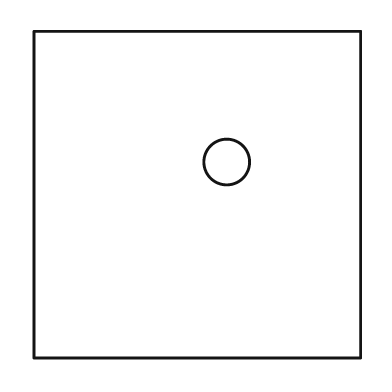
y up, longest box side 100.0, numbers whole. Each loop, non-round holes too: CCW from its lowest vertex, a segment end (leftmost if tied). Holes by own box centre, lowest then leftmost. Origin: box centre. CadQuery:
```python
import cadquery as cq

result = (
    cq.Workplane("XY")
    .moveTo(-50.0, -50.0)
    .lineTo(50.0, -50.0)
    .lineTo(50.0, 50.0)
    .lineTo(-50.0, 50.0)
    .close()
    .moveTo(9.0, 10.0)
    .circle(7.0)
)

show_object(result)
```